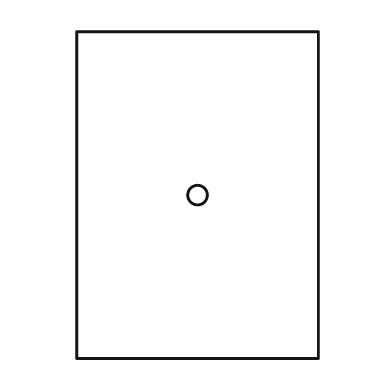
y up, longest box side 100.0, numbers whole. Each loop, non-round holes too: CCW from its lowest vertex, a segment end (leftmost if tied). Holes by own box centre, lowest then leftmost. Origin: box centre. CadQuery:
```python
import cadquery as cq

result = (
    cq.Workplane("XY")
    .moveTo(-37.0, -50.0)
    .lineTo(37.0, -50.0)
    .lineTo(37.0, 50.0)
    .lineTo(-37.0, 50.0)
    .close()
    .moveTo(0.0, 0.0)
    .circle(3.0)
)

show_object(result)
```